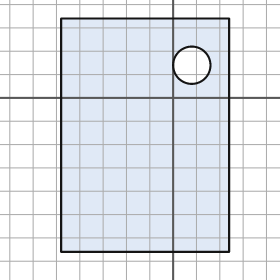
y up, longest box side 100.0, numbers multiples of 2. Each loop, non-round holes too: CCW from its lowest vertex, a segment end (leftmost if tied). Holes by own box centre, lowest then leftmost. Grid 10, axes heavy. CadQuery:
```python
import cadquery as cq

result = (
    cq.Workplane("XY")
    .moveTo(-48.0, -66.0)
    .lineTo(24.0, -66.0)
    .lineTo(24.0, 34.0)
    .lineTo(-48.0, 34.0)
    .close()
    .moveTo(8.0, 14.0)
    .circle(8.0)
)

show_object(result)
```